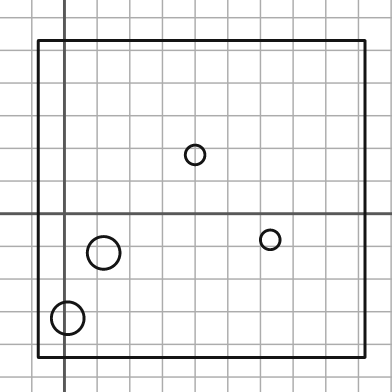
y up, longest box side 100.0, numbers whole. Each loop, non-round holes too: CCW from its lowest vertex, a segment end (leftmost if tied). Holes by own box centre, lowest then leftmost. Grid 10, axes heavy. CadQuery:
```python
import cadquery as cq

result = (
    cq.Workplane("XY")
    .moveTo(-8.0, -44.0)
    .lineTo(92.0, -44.0)
    .lineTo(92.0, 53.0)
    .lineTo(-8.0, 53.0)
    .close()
    .moveTo(1.0, -32.0)
    .circle(5.0)
    .moveTo(12.0, -12.0)
    .circle(5.0)
    .moveTo(63.0, -8.0)
    .circle(3.0)
    .moveTo(40.0, 18.0)
    .circle(3.0)
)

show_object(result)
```